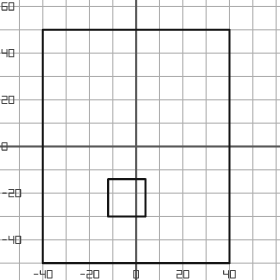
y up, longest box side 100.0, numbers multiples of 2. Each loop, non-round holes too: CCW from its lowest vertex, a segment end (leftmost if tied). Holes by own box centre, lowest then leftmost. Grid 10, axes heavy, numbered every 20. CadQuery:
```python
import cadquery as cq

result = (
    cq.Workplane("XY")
    .moveTo(-40.0, -50.0)
    .lineTo(40.0, -50.0)
    .lineTo(40.0, 50.0)
    .lineTo(-40.0, 50.0)
    .close()
    .moveTo(-12.0, -30.0)
    .lineTo(4.0, -30.0)
    .lineTo(4.0, -14.0)
    .lineTo(-12.0, -14.0)
    .close()
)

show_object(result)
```